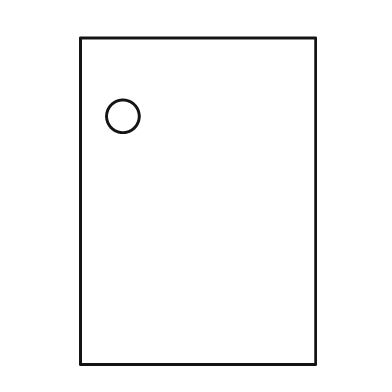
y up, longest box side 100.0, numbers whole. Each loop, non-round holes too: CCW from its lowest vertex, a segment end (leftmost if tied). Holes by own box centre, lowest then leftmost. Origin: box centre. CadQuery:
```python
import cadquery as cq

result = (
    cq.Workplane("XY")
    .moveTo(-36.0, -50.0)
    .lineTo(36.0, -50.0)
    .lineTo(36.0, 50.0)
    .lineTo(-36.0, 50.0)
    .close()
    .moveTo(-23.0, 26.0)
    .circle(5.0)
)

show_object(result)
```